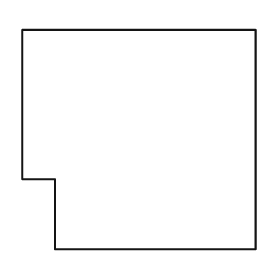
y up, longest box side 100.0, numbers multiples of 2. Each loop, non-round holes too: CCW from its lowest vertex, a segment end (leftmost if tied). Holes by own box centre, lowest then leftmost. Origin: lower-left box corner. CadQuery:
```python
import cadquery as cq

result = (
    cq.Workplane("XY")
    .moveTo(14.0, 0.0)
    .lineTo(100.0, 0.0)
    .lineTo(100.0, 94.0)
    .lineTo(0.0, 94.0)
    .lineTo(0.0, 30.0)
    .lineTo(14.0, 30.0)
    .close()
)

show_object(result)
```